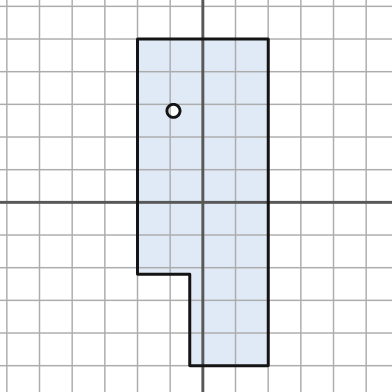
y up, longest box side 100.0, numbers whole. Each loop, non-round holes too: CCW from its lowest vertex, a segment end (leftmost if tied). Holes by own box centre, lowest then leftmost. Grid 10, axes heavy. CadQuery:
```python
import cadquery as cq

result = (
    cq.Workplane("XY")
    .moveTo(-4.0, -50.0)
    .lineTo(20.0, -50.0)
    .lineTo(20.0, 50.0)
    .lineTo(-20.0, 50.0)
    .lineTo(-20.0, -22.0)
    .lineTo(-4.0, -22.0)
    .close()
    .moveTo(-9.0, 28.0)
    .circle(2.0)
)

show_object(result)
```